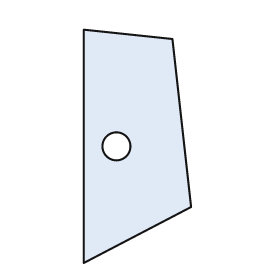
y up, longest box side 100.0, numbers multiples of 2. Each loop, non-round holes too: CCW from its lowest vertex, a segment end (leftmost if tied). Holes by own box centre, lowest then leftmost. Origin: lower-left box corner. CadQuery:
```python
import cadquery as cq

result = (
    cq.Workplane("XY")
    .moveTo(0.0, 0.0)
    .lineTo(46.0, 24.0)
    .lineTo(38.0, 96.0)
    .lineTo(0.0, 100.0)
    .close()
    .moveTo(14.0, 50.0)
    .circle(6.0)
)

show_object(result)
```